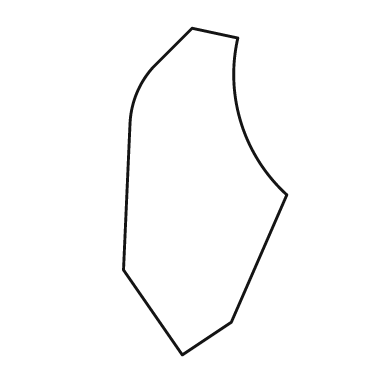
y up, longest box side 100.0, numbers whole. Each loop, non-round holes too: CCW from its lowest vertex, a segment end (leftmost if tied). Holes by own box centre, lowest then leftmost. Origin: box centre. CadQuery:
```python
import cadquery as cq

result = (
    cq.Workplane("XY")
    .moveTo(-7.0, -50.0)
    .lineTo(8.0, -40.0)
    .lineTo(25.0, -1.0)
    .threePointArc((11.0, 21.0), (10.0, 47.0))
    .lineTo(-4.0, 50.0)
    .lineTo(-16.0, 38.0)
    .threePointArc((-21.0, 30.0), (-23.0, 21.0))
    .lineTo(-25.0, -24.0)
    .close()
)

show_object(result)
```